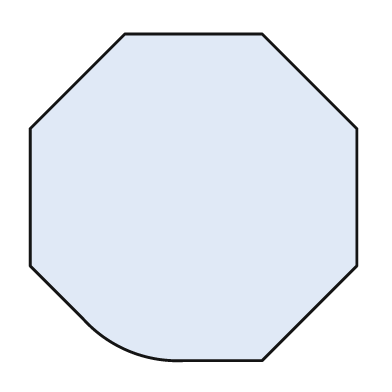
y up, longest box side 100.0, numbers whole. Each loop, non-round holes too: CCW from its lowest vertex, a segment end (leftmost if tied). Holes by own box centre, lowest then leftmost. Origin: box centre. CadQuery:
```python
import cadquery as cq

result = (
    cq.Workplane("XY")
    .moveTo(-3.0, -50.0)
    .lineTo(21.0, -50.0)
    .lineTo(50.0, -21.0)
    .lineTo(50.0, 21.0)
    .lineTo(21.0, 50.0)
    .lineTo(-21.0, 50.0)
    .lineTo(-50.0, 21.0)
    .lineTo(-50.0, -21.0)
    .lineTo(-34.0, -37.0)
    .threePointArc((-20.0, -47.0), (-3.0, -50.0))
    .close()
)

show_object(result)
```